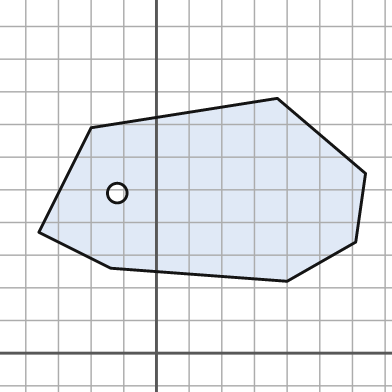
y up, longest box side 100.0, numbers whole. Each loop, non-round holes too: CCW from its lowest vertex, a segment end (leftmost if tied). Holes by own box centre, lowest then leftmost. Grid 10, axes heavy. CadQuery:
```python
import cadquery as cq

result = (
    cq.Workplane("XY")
    .moveTo(40.0, 22.0)
    .lineTo(61.0, 34.0)
    .lineTo(64.0, 55.0)
    .lineTo(37.0, 78.0)
    .lineTo(-20.0, 69.0)
    .lineTo(-36.0, 37.0)
    .lineTo(-14.0, 26.0)
    .close()
    .moveTo(-12.0, 49.0)
    .circle(3.0)
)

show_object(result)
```